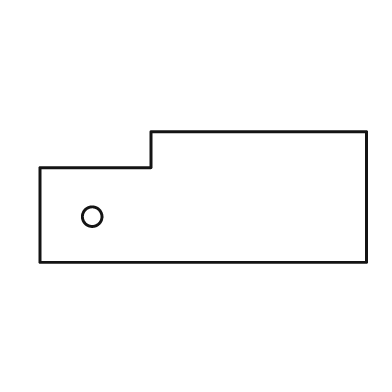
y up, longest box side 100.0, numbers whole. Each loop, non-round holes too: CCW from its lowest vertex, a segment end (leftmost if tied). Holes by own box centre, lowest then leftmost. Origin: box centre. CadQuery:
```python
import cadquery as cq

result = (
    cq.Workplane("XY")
    .moveTo(-50.0, -20.0)
    .lineTo(50.0, -20.0)
    .lineTo(50.0, 20.0)
    .lineTo(-16.0, 20.0)
    .lineTo(-16.0, 9.0)
    .lineTo(-50.0, 9.0)
    .close()
    .moveTo(-34.0, -6.0)
    .circle(3.0)
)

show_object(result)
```